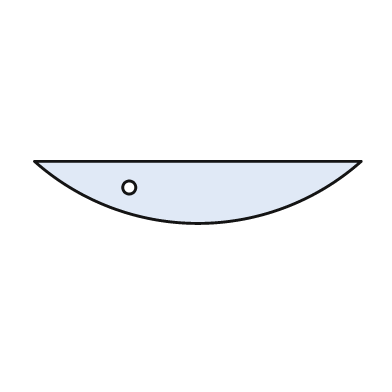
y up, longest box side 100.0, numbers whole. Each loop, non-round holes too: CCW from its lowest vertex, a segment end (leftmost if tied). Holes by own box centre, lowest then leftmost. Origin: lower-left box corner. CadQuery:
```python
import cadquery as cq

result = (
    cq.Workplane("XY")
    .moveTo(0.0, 19.0)
    .threePointArc((50.0, 0.0), (100.0, 19.0))
    .close()
    .moveTo(29.0, 11.0)
    .circle(2.0)
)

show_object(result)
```